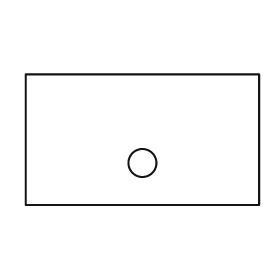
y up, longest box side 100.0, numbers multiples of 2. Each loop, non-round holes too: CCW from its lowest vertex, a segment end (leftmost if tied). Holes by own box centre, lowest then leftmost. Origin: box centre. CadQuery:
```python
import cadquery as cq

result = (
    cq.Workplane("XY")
    .moveTo(-50.0, -28.0)
    .lineTo(50.0, -28.0)
    .lineTo(50.0, 28.0)
    .lineTo(-50.0, 28.0)
    .close()
    .moveTo(0.0, -10.0)
    .circle(6.0)
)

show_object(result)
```